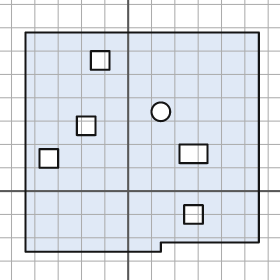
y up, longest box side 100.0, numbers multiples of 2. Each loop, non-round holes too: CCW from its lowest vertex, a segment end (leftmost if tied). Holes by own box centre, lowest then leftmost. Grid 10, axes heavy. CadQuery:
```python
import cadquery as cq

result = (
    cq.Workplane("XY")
    .moveTo(-44.0, -26.0)
    .lineTo(14.0, -26.0)
    .lineTo(14.0, -22.0)
    .lineTo(56.0, -22.0)
    .lineTo(56.0, 68.0)
    .lineTo(-44.0, 68.0)
    .close()
    .moveTo(24.0, -14.0)
    .lineTo(32.0, -14.0)
    .lineTo(32.0, -6.0)
    .lineTo(24.0, -6.0)
    .close()
    .moveTo(-38.0, 10.0)
    .lineTo(-30.0, 10.0)
    .lineTo(-30.0, 18.0)
    .lineTo(-38.0, 18.0)
    .close()
    .moveTo(22.0, 12.0)
    .lineTo(34.0, 12.0)
    .lineTo(34.0, 20.0)
    .lineTo(22.0, 20.0)
    .close()
    .moveTo(-22.0, 24.0)
    .lineTo(-14.0, 24.0)
    .lineTo(-14.0, 32.0)
    .lineTo(-22.0, 32.0)
    .close()
    .moveTo(14.0, 34.0)
    .circle(4.0)
    .moveTo(-16.0, 52.0)
    .lineTo(-8.0, 52.0)
    .lineTo(-8.0, 60.0)
    .lineTo(-16.0, 60.0)
    .close()
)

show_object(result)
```